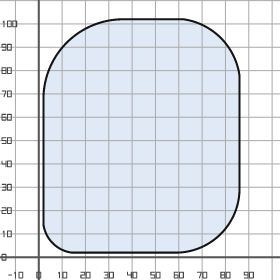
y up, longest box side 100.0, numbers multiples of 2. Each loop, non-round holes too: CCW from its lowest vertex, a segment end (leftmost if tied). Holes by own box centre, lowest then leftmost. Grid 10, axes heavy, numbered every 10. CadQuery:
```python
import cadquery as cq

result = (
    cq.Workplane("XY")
    .moveTo(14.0, 2.0)
    .lineTo(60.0, 2.0)
    .threePointArc((78.0, 10.0), (86.0, 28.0))
    .lineTo(86.0, 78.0)
    .threePointArc((78.0, 94.0), (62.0, 102.0))
    .lineTo(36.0, 102.0)
    .threePointArc((12.0, 92.0), (2.0, 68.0))
    .lineTo(2.0, 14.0)
    .threePointArc((6.0, 6.0), (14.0, 2.0))
    .close()
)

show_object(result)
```